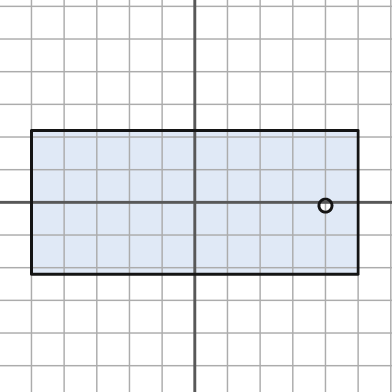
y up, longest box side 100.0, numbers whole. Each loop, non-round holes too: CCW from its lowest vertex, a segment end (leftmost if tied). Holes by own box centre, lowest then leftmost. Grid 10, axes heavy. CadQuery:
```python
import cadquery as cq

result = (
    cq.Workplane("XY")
    .moveTo(-50.0, -22.0)
    .lineTo(50.0, -22.0)
    .lineTo(50.0, 22.0)
    .lineTo(-50.0, 22.0)
    .close()
    .moveTo(40.0, -1.0)
    .circle(2.0)
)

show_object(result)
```